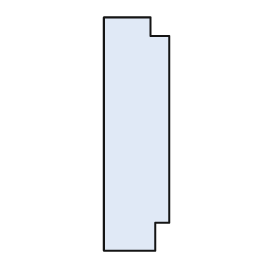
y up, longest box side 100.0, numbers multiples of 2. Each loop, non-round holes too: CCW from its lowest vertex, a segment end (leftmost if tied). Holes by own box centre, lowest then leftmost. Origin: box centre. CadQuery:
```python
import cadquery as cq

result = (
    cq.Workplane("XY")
    .moveTo(-14.0, -50.0)
    .lineTo(8.0, -50.0)
    .lineTo(8.0, -38.0)
    .lineTo(14.0, -38.0)
    .lineTo(14.0, 42.0)
    .lineTo(6.0, 42.0)
    .lineTo(6.0, 50.0)
    .lineTo(-14.0, 50.0)
    .close()
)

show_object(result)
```